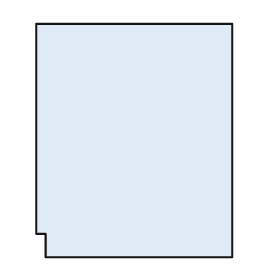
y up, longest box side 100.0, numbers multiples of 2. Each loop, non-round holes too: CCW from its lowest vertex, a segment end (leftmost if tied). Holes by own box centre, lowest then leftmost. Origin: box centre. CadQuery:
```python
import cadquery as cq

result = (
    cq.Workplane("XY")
    .moveTo(-38.0, -50.0)
    .lineTo(42.0, -50.0)
    .lineTo(42.0, 50.0)
    .lineTo(-42.0, 50.0)
    .lineTo(-42.0, -40.0)
    .lineTo(-38.0, -40.0)
    .close()
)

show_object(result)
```